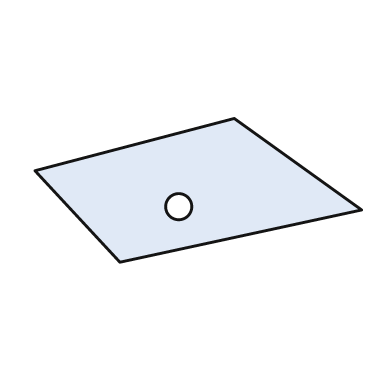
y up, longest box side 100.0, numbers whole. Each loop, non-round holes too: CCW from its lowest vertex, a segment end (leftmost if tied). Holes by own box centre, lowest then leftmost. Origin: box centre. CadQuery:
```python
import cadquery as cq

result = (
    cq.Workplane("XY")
    .moveTo(-24.0, -22.0)
    .lineTo(50.0, -6.0)
    .lineTo(11.0, 22.0)
    .lineTo(-50.0, 6.0)
    .close()
    .moveTo(-6.0, -5.0)
    .circle(4.0)
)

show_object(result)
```